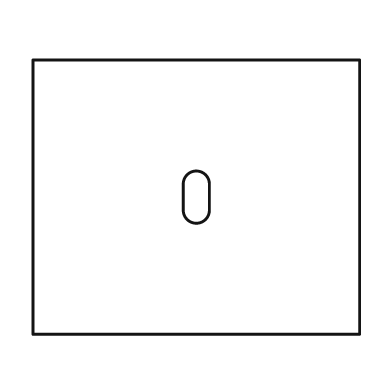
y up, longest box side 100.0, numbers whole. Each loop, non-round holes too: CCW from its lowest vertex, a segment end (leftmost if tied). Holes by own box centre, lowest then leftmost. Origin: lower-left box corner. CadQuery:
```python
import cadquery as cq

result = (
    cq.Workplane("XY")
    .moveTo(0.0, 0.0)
    .lineTo(100.0, 0.0)
    .lineTo(100.0, 84.0)
    .lineTo(0.0, 84.0)
    .close()
    .moveTo(46.0, 38.0)
    .threePointArc((50.0, 34.0), (54.0, 38.0))
    .lineTo(54.0, 46.0)
    .threePointArc((50.0, 50.0), (46.0, 46.0))
    .close()
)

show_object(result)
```